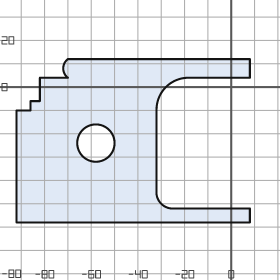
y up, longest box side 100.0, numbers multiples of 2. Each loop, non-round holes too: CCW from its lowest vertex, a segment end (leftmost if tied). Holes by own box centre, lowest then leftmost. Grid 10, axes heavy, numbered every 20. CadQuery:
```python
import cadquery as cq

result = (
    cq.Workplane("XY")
    .moveTo(-92.0, -58.0)
    .lineTo(8.0, -58.0)
    .lineTo(8.0, -52.0)
    .lineTo(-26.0, -52.0)
    .threePointArc((-30.0, -50.0), (-32.0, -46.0))
    .lineTo(-32.0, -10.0)
    .threePointArc((-28.0, 0.0), (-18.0, 4.0))
    .lineTo(8.0, 4.0)
    .lineTo(8.0, 12.0)
    .lineTo(-70.0, 12.0)
    .threePointArc((-72.0, 8.0), (-70.0, 4.0))
    .lineTo(-82.0, 4.0)
    .lineTo(-82.0, -6.0)
    .lineTo(-86.0, -6.0)
    .lineTo(-86.0, -10.0)
    .lineTo(-92.0, -10.0)
    .close()
    .moveTo(-58.0, -24.0)
    .circle(8.0)
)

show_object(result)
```